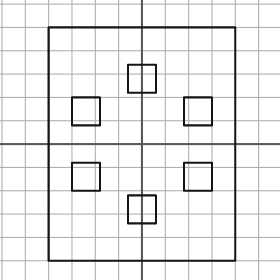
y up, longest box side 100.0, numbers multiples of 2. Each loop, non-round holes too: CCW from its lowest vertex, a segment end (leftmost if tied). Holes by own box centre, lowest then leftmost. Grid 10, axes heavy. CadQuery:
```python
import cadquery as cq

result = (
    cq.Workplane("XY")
    .moveTo(-40.0, -50.0)
    .lineTo(40.0, -50.0)
    .lineTo(40.0, 50.0)
    .lineTo(-40.0, 50.0)
    .close()
    .moveTo(-6.0, -34.0)
    .lineTo(6.0, -34.0)
    .lineTo(6.0, -22.0)
    .lineTo(-6.0, -22.0)
    .close()
    .moveTo(-30.0, -20.0)
    .lineTo(-18.0, -20.0)
    .lineTo(-18.0, -8.0)
    .lineTo(-30.0, -8.0)
    .close()
    .moveTo(18.0, -20.0)
    .lineTo(30.0, -20.0)
    .lineTo(30.0, -8.0)
    .lineTo(18.0, -8.0)
    .close()
    .moveTo(-30.0, 8.0)
    .lineTo(-18.0, 8.0)
    .lineTo(-18.0, 20.0)
    .lineTo(-30.0, 20.0)
    .close()
    .moveTo(18.0, 8.0)
    .lineTo(30.0, 8.0)
    .lineTo(30.0, 20.0)
    .lineTo(18.0, 20.0)
    .close()
    .moveTo(-6.0, 22.0)
    .lineTo(6.0, 22.0)
    .lineTo(6.0, 34.0)
    .lineTo(-6.0, 34.0)
    .close()
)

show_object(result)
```